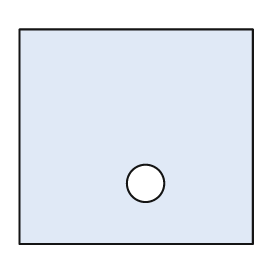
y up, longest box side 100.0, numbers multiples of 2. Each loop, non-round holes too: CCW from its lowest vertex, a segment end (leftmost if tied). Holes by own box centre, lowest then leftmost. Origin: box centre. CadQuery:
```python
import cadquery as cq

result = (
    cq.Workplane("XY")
    .moveTo(-50.0, -46.0)
    .lineTo(50.0, -46.0)
    .lineTo(50.0, 46.0)
    .lineTo(-50.0, 46.0)
    .close()
    .moveTo(4.0, -20.0)
    .circle(8.0)
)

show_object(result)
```